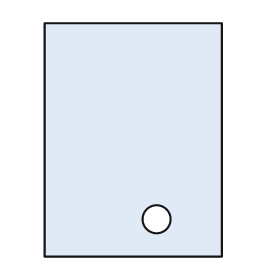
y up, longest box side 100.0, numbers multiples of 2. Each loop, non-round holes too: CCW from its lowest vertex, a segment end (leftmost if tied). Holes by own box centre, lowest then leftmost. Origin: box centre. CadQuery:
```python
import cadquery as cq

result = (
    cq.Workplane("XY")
    .moveTo(-38.0, -50.0)
    .lineTo(38.0, -50.0)
    .lineTo(38.0, 50.0)
    .lineTo(-38.0, 50.0)
    .close()
    .moveTo(10.0, -34.0)
    .circle(6.0)
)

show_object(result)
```